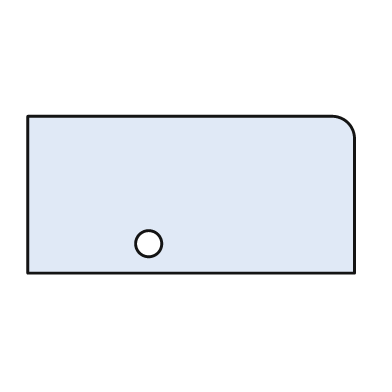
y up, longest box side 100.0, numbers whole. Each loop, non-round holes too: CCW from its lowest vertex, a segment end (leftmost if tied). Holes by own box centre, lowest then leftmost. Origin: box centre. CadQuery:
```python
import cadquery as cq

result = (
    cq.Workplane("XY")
    .moveTo(-50.0, -24.0)
    .lineTo(50.0, -24.0)
    .lineTo(50.0, 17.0)
    .threePointArc((48.0, 22.0), (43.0, 24.0))
    .lineTo(-50.0, 24.0)
    .close()
    .moveTo(-13.0, -15.0)
    .circle(4.0)
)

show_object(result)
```